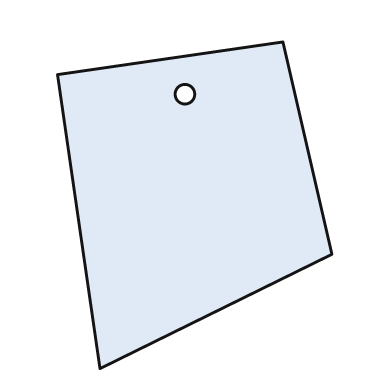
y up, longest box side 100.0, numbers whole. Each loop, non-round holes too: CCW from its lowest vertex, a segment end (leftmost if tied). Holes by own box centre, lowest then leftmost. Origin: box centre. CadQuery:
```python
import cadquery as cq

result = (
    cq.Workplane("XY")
    .moveTo(-29.0, -50.0)
    .lineTo(42.0, -15.0)
    .lineTo(27.0, 50.0)
    .lineTo(-42.0, 40.0)
    .close()
    .moveTo(-3.0, 34.0)
    .circle(3.0)
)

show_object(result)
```